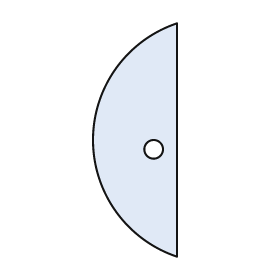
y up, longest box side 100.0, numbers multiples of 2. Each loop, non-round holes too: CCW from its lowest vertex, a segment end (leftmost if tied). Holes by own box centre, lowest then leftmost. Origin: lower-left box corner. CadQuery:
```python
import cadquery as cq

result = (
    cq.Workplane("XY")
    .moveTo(36.0, 0.0)
    .lineTo(36.0, 100.0)
    .threePointArc((0.0, 50.0), (36.0, 0.0))
    .close()
    .moveTo(26.0, 46.0)
    .circle(4.0)
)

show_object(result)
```